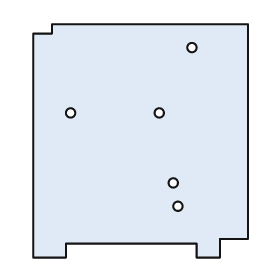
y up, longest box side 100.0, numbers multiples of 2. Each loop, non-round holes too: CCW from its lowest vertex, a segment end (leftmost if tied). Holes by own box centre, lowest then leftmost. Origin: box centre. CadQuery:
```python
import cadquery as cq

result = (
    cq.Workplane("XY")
    .moveTo(-46.0, -50.0)
    .lineTo(-32.0, -50.0)
    .lineTo(-32.0, -44.0)
    .lineTo(24.0, -44.0)
    .lineTo(24.0, -50.0)
    .lineTo(34.0, -50.0)
    .lineTo(34.0, -42.0)
    .lineTo(46.0, -42.0)
    .lineTo(46.0, 50.0)
    .lineTo(-38.0, 50.0)
    .lineTo(-38.0, 46.0)
    .lineTo(-46.0, 46.0)
    .close()
    .moveTo(16.0, -28.0)
    .circle(2.0)
    .moveTo(14.0, -18.0)
    .circle(2.0)
    .moveTo(-30.0, 12.0)
    .circle(2.0)
    .moveTo(8.0, 12.0)
    .circle(2.0)
    .moveTo(22.0, 40.0)
    .circle(2.0)
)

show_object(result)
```